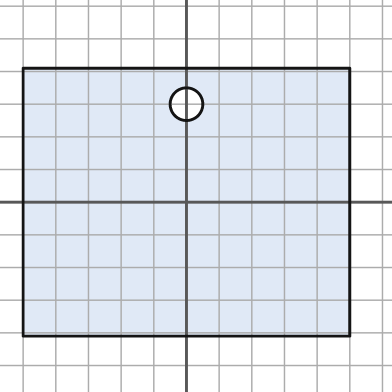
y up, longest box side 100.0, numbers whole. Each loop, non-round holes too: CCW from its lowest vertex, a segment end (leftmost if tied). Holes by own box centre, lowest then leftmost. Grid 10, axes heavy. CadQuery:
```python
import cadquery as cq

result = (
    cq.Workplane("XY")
    .moveTo(-50.0, -41.0)
    .lineTo(50.0, -41.0)
    .lineTo(50.0, 41.0)
    .lineTo(-50.0, 41.0)
    .close()
    .moveTo(0.0, 30.0)
    .circle(5.0)
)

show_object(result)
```